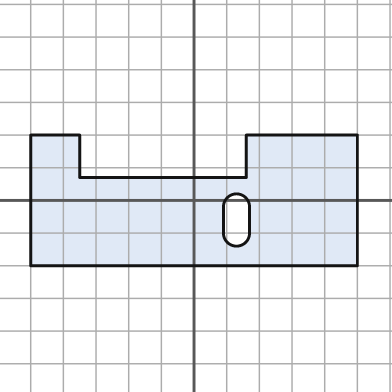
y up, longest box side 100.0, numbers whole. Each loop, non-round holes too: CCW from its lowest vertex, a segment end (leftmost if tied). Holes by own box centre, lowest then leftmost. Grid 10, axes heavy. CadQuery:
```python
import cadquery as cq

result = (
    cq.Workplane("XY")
    .moveTo(-50.0, -20.0)
    .lineTo(50.0, -20.0)
    .lineTo(50.0, 20.0)
    .lineTo(16.0, 20.0)
    .lineTo(16.0, 7.0)
    .lineTo(-35.0, 7.0)
    .lineTo(-35.0, 20.0)
    .lineTo(-50.0, 20.0)
    .close()
    .moveTo(9.0, -10.0)
    .threePointArc((13.0, -14.0), (17.0, -10.0))
    .lineTo(17.0, -2.0)
    .threePointArc((13.0, 2.0), (9.0, -2.0))
    .close()
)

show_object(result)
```